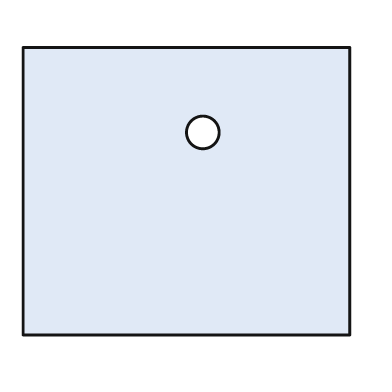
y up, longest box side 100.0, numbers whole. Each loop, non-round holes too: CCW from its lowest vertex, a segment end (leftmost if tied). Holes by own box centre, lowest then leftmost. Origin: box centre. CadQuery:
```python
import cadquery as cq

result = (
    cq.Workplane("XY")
    .moveTo(-50.0, -44.0)
    .lineTo(50.0, -44.0)
    .lineTo(50.0, 44.0)
    .lineTo(-50.0, 44.0)
    .close()
    .moveTo(5.0, 18.0)
    .circle(5.0)
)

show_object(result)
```